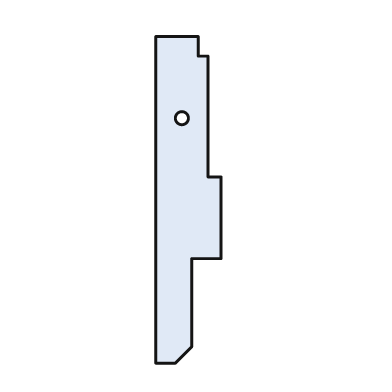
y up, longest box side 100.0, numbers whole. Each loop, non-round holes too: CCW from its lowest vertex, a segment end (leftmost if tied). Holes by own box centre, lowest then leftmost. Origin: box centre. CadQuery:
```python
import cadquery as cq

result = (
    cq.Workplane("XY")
    .moveTo(-10.0, -50.0)
    .lineTo(-4.0, -50.0)
    .lineTo(1.0, -45.0)
    .lineTo(1.0, -18.0)
    .lineTo(10.0, -18.0)
    .lineTo(10.0, 7.0)
    .lineTo(6.0, 7.0)
    .lineTo(6.0, 44.0)
    .lineTo(3.0, 44.0)
    .lineTo(3.0, 50.0)
    .lineTo(-10.0, 50.0)
    .close()
    .moveTo(-2.0, 25.0)
    .circle(2.0)
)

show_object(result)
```